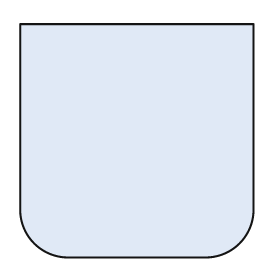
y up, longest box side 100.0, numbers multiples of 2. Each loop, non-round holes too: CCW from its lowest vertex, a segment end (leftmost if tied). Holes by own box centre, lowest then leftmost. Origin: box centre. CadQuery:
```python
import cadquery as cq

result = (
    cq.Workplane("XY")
    .moveTo(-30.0, -50.0)
    .lineTo(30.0, -50.0)
    .threePointArc((44.0, -44.0), (50.0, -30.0))
    .lineTo(50.0, 50.0)
    .lineTo(-50.0, 50.0)
    .lineTo(-50.0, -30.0)
    .threePointArc((-44.0, -44.0), (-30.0, -50.0))
    .close()
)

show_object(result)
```